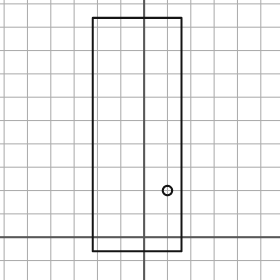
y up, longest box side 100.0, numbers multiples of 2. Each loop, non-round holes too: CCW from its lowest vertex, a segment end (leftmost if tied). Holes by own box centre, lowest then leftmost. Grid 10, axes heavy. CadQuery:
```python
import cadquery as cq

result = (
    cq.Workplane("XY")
    .moveTo(-22.0, -6.0)
    .lineTo(16.0, -6.0)
    .lineTo(16.0, 94.0)
    .lineTo(-22.0, 94.0)
    .close()
    .moveTo(10.0, 20.0)
    .circle(2.0)
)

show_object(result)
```